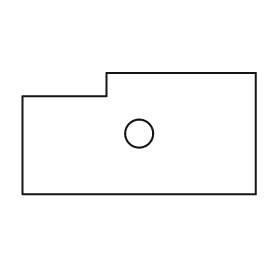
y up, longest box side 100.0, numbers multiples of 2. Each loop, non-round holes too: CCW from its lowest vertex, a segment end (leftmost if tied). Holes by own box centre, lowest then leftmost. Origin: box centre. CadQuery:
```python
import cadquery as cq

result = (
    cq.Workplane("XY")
    .moveTo(-50.0, -26.0)
    .lineTo(50.0, -26.0)
    .lineTo(50.0, 26.0)
    .lineTo(-14.0, 26.0)
    .lineTo(-14.0, 16.0)
    .lineTo(-50.0, 16.0)
    .close()
    .moveTo(0.0, 0.0)
    .circle(6.0)
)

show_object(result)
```